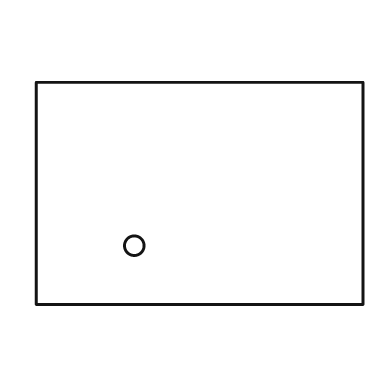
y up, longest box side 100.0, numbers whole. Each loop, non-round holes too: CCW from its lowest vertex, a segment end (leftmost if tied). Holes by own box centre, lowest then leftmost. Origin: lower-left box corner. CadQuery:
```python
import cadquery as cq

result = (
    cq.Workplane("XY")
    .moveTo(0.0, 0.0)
    .lineTo(100.0, 0.0)
    .lineTo(100.0, 68.0)
    .lineTo(0.0, 68.0)
    .close()
    .moveTo(30.0, 18.0)
    .circle(3.0)
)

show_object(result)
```